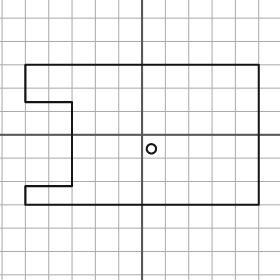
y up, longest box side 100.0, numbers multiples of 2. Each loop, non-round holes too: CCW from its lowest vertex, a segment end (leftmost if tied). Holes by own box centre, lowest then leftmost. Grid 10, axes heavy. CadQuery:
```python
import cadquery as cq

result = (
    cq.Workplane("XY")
    .moveTo(-50.0, -30.0)
    .lineTo(50.0, -30.0)
    .lineTo(50.0, 30.0)
    .lineTo(-50.0, 30.0)
    .lineTo(-50.0, 14.0)
    .lineTo(-30.0, 14.0)
    .lineTo(-30.0, -22.0)
    .lineTo(-50.0, -22.0)
    .close()
    .moveTo(4.0, -6.0)
    .circle(2.0)
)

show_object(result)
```